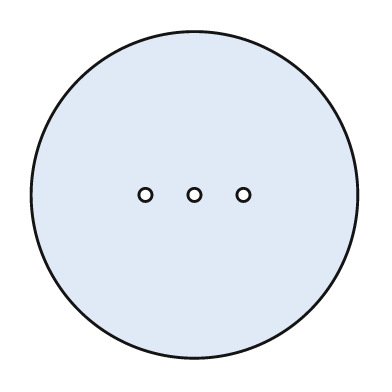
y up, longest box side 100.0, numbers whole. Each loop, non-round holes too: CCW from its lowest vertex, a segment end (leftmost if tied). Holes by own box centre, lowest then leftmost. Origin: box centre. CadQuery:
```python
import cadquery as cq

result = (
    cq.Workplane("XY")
    .moveTo(0.0, 0.0)
    .circle(50.0)
    .moveTo(-15.0, 0.0)
    .circle(2.0)
    .moveTo(0.0, 0.0)
    .circle(2.0)
    .moveTo(15.0, 0.0)
    .circle(2.0)
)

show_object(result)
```